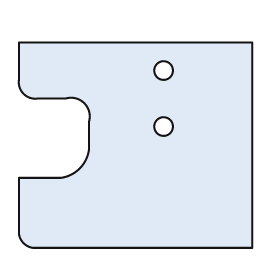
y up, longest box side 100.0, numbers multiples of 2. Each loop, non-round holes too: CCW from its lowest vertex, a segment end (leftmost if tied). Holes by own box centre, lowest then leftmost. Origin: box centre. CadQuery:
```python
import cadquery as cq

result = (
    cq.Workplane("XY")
    .moveTo(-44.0, -44.0)
    .lineTo(50.0, -44.0)
    .lineTo(50.0, 44.0)
    .lineTo(-50.0, 44.0)
    .lineTo(-50.0, 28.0)
    .threePointArc((-48.0, 22.0), (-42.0, 20.0))
    .lineTo(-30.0, 20.0)
    .threePointArc((-22.0, 18.0), (-20.0, 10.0))
    .lineTo(-20.0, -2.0)
    .threePointArc((-24.0, -10.0), (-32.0, -14.0))
    .lineTo(-50.0, -14.0)
    .lineTo(-50.0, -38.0)
    .threePointArc((-48.0, -42.0), (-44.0, -44.0))
    .close()
    .moveTo(12.0, 8.0)
    .circle(4.0)
    .moveTo(12.0, 32.0)
    .circle(4.0)
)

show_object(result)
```